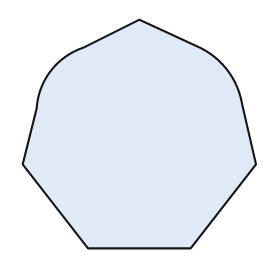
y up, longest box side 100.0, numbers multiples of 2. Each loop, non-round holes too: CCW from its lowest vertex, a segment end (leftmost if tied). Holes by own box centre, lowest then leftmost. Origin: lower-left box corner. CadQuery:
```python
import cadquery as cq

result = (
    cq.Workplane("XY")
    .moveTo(28.0, 0.0)
    .lineTo(72.0, 0.0)
    .lineTo(100.0, 36.0)
    .lineTo(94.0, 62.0)
    .threePointArc((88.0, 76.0), (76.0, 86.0))
    .lineTo(50.0, 98.0)
    .lineTo(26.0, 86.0)
    .threePointArc((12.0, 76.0), (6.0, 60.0))
    .lineTo(0.0, 36.0)
    .close()
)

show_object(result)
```